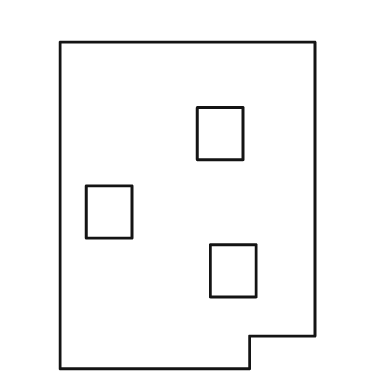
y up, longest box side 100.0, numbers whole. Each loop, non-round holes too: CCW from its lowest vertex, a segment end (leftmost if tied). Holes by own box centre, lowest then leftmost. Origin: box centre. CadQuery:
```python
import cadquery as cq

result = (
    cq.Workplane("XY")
    .moveTo(-39.0, -50.0)
    .lineTo(19.0, -50.0)
    .lineTo(19.0, -40.0)
    .lineTo(39.0, -40.0)
    .lineTo(39.0, 50.0)
    .lineTo(-39.0, 50.0)
    .close()
    .moveTo(7.0, -28.0)
    .lineTo(21.0, -28.0)
    .lineTo(21.0, -12.0)
    .lineTo(7.0, -12.0)
    .close()
    .moveTo(-31.0, -10.0)
    .lineTo(-17.0, -10.0)
    .lineTo(-17.0, 6.0)
    .lineTo(-31.0, 6.0)
    .close()
    .moveTo(3.0, 14.0)
    .lineTo(17.0, 14.0)
    .lineTo(17.0, 30.0)
    .lineTo(3.0, 30.0)
    .close()
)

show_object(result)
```